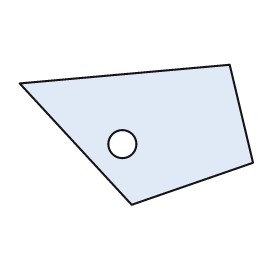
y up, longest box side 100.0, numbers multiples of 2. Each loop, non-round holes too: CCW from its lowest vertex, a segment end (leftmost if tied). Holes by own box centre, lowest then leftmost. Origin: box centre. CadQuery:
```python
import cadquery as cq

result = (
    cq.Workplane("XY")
    .moveTo(-2.0, -30.0)
    .lineTo(50.0, -12.0)
    .lineTo(40.0, 30.0)
    .lineTo(-50.0, 22.0)
    .close()
    .moveTo(-6.0, -4.0)
    .circle(6.0)
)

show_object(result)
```